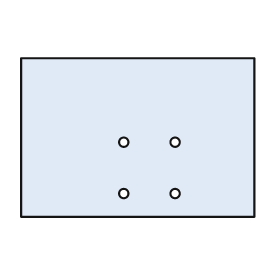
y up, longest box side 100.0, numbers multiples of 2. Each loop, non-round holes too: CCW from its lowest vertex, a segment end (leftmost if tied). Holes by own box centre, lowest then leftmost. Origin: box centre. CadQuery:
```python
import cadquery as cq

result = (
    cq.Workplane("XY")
    .moveTo(-50.0, -34.0)
    .lineTo(50.0, -34.0)
    .lineTo(50.0, 34.0)
    .lineTo(-50.0, 34.0)
    .close()
    .moveTo(-6.0, -24.0)
    .circle(2.0)
    .moveTo(16.0, -24.0)
    .circle(2.0)
    .moveTo(-6.0, -2.0)
    .circle(2.0)
    .moveTo(16.0, -2.0)
    .circle(2.0)
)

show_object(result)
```